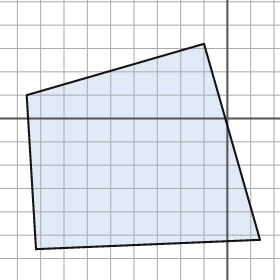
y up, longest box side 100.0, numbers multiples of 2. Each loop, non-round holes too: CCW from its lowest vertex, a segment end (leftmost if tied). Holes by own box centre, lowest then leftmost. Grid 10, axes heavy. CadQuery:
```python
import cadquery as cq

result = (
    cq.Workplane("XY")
    .moveTo(-82.0, -56.0)
    .lineTo(14.0, -52.0)
    .lineTo(-10.0, 32.0)
    .lineTo(-86.0, 10.0)
    .close()
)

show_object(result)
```